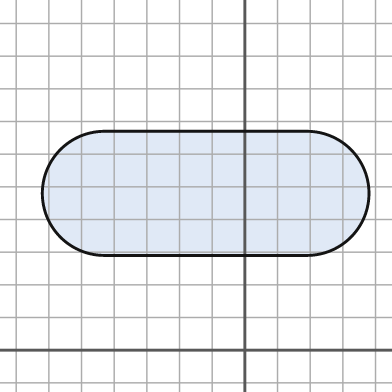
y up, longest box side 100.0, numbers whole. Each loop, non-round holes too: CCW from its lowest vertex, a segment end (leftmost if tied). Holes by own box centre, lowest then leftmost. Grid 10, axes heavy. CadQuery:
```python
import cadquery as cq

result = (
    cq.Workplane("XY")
    .moveTo(-43.0, 29.0)
    .lineTo(19.0, 29.0)
    .threePointArc((38.0, 48.0), (19.0, 67.0))
    .lineTo(-43.0, 67.0)
    .threePointArc((-62.0, 48.0), (-43.0, 29.0))
    .close()
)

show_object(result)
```